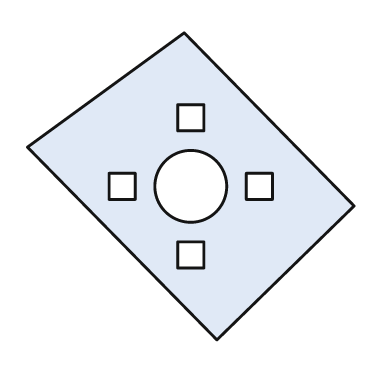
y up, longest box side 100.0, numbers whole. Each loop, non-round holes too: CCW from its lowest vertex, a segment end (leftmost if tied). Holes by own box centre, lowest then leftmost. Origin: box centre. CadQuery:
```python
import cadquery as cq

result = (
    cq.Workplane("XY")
    .moveTo(8.0, -47.0)
    .lineTo(50.0, -6.0)
    .lineTo(-2.0, 47.0)
    .lineTo(-50.0, 12.0)
    .close()
    .moveTo(-4.0, -25.0)
    .lineTo(4.0, -25.0)
    .lineTo(4.0, -17.0)
    .lineTo(-4.0, -17.0)
    .close()
    .moveTo(-25.0, -4.0)
    .lineTo(-17.0, -4.0)
    .lineTo(-17.0, 4.0)
    .lineTo(-25.0, 4.0)
    .close()
    .moveTo(0.0, 0.0)
    .circle(11.0)
    .moveTo(17.0, -4.0)
    .lineTo(25.0, -4.0)
    .lineTo(25.0, 4.0)
    .lineTo(17.0, 4.0)
    .close()
    .moveTo(-4.0, 17.0)
    .lineTo(4.0, 17.0)
    .lineTo(4.0, 25.0)
    .lineTo(-4.0, 25.0)
    .close()
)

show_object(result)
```